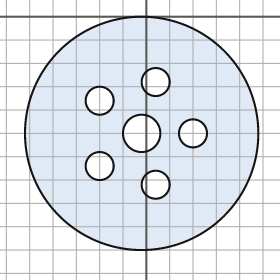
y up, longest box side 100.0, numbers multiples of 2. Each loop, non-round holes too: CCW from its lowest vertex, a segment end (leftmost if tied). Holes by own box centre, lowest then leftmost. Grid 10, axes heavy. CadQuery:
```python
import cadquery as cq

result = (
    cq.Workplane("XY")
    .moveTo(-2.0, -50.0)
    .circle(50.0)
    .moveTo(4.0, -72.0)
    .circle(6.0)
    .moveTo(-20.0, -64.0)
    .circle(6.0)
    .moveTo(-2.0, -50.0)
    .circle(8.0)
    .moveTo(20.0, -50.0)
    .circle(6.0)
    .moveTo(-20.0, -36.0)
    .circle(6.0)
    .moveTo(4.0, -28.0)
    .circle(6.0)
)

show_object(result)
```